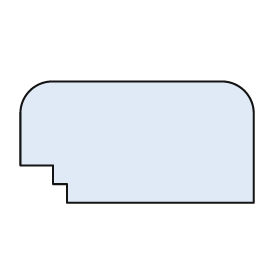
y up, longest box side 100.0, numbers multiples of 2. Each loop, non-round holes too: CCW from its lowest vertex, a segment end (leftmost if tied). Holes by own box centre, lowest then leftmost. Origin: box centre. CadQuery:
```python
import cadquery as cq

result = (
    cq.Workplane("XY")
    .moveTo(-30.0, -26.0)
    .lineTo(50.0, -26.0)
    .lineTo(50.0, 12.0)
    .threePointArc((46.0, 22.0), (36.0, 26.0))
    .lineTo(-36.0, 26.0)
    .threePointArc((-46.0, 22.0), (-50.0, 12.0))
    .lineTo(-50.0, -10.0)
    .lineTo(-36.0, -10.0)
    .lineTo(-36.0, -18.0)
    .lineTo(-30.0, -18.0)
    .close()
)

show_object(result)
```